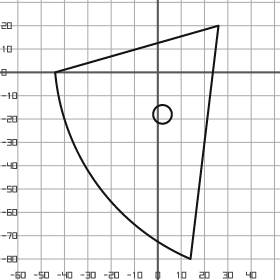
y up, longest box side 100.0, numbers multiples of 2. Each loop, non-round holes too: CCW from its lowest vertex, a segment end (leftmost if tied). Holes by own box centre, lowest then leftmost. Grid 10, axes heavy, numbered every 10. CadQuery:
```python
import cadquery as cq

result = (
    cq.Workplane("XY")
    .moveTo(14.0, -80.0)
    .lineTo(26.0, 20.0)
    .lineTo(-44.0, 0.0)
    .threePointArc((-26.0, -48.0), (14.0, -80.0))
    .close()
    .moveTo(2.0, -18.0)
    .circle(4.0)
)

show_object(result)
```